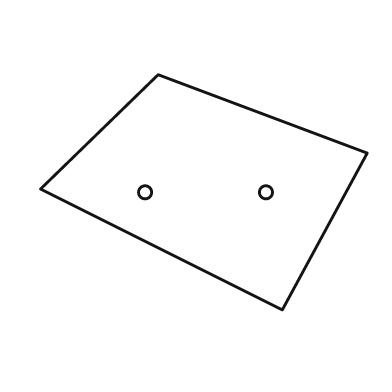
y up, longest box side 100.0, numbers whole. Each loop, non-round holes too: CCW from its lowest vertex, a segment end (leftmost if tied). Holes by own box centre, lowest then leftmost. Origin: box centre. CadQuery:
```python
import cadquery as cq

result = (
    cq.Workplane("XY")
    .moveTo(24.0, -36.0)
    .lineTo(50.0, 12.0)
    .lineTo(-14.0, 36.0)
    .lineTo(-50.0, 1.0)
    .close()
    .moveTo(-18.0, 0.0)
    .circle(2.0)
    .moveTo(19.0, 0.0)
    .circle(2.0)
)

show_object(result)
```